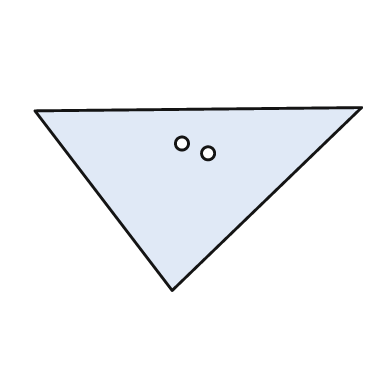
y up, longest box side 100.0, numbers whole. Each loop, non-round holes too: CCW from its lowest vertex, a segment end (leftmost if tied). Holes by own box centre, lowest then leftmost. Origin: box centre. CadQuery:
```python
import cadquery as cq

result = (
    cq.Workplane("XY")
    .moveTo(-8.0, -28.0)
    .lineTo(50.0, 28.0)
    .lineTo(-50.0, 27.0)
    .close()
    .moveTo(3.0, 14.0)
    .circle(2.0)
    .moveTo(-5.0, 17.0)
    .circle(2.0)
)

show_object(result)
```